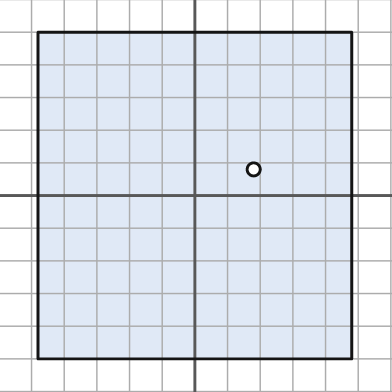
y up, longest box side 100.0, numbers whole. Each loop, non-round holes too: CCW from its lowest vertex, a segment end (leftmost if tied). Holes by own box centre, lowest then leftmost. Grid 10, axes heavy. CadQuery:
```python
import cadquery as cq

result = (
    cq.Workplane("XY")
    .moveTo(-48.0, -50.0)
    .lineTo(48.0, -50.0)
    .lineTo(48.0, 50.0)
    .lineTo(-48.0, 50.0)
    .close()
    .moveTo(18.0, 8.0)
    .circle(2.0)
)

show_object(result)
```